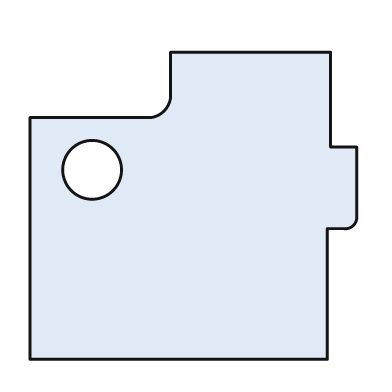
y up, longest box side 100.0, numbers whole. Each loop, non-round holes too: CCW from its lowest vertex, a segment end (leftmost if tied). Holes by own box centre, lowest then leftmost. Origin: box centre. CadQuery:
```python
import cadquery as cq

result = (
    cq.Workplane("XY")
    .moveTo(-50.0, -47.0)
    .lineTo(41.0, -47.0)
    .lineTo(41.0, -7.0)
    .lineTo(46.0, -7.0)
    .threePointArc((49.0, -6.0), (50.0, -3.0))
    .lineTo(50.0, 18.0)
    .lineTo(42.0, 18.0)
    .lineTo(42.0, 47.0)
    .lineTo(-7.0, 47.0)
    .lineTo(-7.0, 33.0)
    .threePointArc((-9.0, 29.0), (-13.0, 27.0))
    .lineTo(-50.0, 27.0)
    .close()
    .moveTo(-31.0, 11.0)
    .circle(9.0)
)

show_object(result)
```